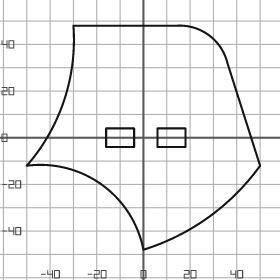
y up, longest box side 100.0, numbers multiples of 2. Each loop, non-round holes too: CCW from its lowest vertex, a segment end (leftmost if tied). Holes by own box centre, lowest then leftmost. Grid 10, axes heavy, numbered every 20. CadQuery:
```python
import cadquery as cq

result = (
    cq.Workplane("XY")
    .moveTo(0.0, -48.0)
    .threePointArc((28.0, -34.0), (50.0, -12.0))
    .lineTo(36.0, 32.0)
    .threePointArc((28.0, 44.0), (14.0, 48.0))
    .lineTo(-30.0, 48.0)
    .threePointArc((-34.0, 16.0), (-50.0, -12.0))
    .threePointArc((-18.0, -20.0), (0.0, -48.0))
    .close()
    .moveTo(-16.0, -4.0)
    .lineTo(-4.0, -4.0)
    .lineTo(-4.0, 4.0)
    .lineTo(-16.0, 4.0)
    .close()
    .moveTo(6.0, -4.0)
    .lineTo(18.0, -4.0)
    .lineTo(18.0, 4.0)
    .lineTo(6.0, 4.0)
    .close()
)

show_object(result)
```